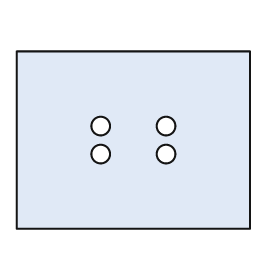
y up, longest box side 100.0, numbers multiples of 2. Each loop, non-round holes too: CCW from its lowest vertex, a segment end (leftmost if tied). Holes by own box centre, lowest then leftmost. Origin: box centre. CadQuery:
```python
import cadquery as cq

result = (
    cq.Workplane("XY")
    .moveTo(-50.0, -38.0)
    .lineTo(50.0, -38.0)
    .lineTo(50.0, 38.0)
    .lineTo(-50.0, 38.0)
    .close()
    .moveTo(-14.0, -6.0)
    .circle(4.0)
    .moveTo(14.0, -6.0)
    .circle(4.0)
    .moveTo(-14.0, 6.0)
    .circle(4.0)
    .moveTo(14.0, 6.0)
    .circle(4.0)
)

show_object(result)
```